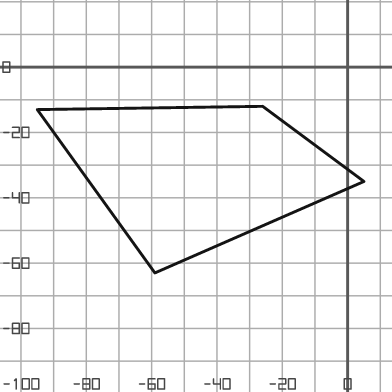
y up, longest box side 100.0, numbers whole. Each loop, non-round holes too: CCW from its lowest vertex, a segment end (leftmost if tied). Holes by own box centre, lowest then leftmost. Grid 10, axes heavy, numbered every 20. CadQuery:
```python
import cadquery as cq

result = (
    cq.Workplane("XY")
    .moveTo(-59.0, -63.0)
    .lineTo(5.0, -35.0)
    .lineTo(-26.0, -12.0)
    .lineTo(-95.0, -13.0)
    .close()
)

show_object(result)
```